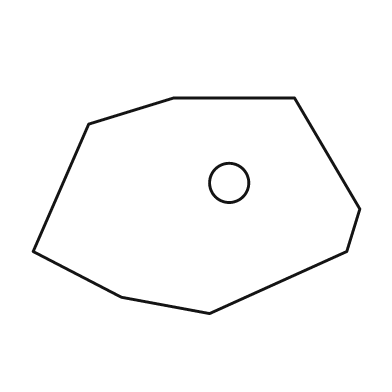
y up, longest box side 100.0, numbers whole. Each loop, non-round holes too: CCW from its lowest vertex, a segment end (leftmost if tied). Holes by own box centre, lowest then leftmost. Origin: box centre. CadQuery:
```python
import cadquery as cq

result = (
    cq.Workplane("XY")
    .moveTo(4.0, -33.0)
    .lineTo(46.0, -14.0)
    .lineTo(50.0, -1.0)
    .lineTo(30.0, 33.0)
    .lineTo(-7.0, 33.0)
    .lineTo(-33.0, 25.0)
    .lineTo(-50.0, -14.0)
    .lineTo(-23.0, -28.0)
    .close()
    .moveTo(10.0, 7.0)
    .circle(6.0)
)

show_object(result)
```